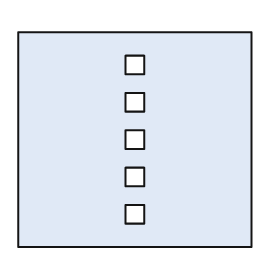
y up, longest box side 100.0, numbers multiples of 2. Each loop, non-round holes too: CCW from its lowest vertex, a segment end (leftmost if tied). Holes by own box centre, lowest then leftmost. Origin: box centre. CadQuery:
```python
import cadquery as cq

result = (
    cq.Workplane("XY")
    .moveTo(-50.0, -46.0)
    .lineTo(50.0, -46.0)
    .lineTo(50.0, 46.0)
    .lineTo(-50.0, 46.0)
    .close()
    .moveTo(-4.0, -36.0)
    .lineTo(4.0, -36.0)
    .lineTo(4.0, -28.0)
    .lineTo(-4.0, -28.0)
    .close()
    .moveTo(-4.0, -20.0)
    .lineTo(4.0, -20.0)
    .lineTo(4.0, -12.0)
    .lineTo(-4.0, -12.0)
    .close()
    .moveTo(-4.0, -4.0)
    .lineTo(4.0, -4.0)
    .lineTo(4.0, 4.0)
    .lineTo(-4.0, 4.0)
    .close()
    .moveTo(-4.0, 12.0)
    .lineTo(4.0, 12.0)
    .lineTo(4.0, 20.0)
    .lineTo(-4.0, 20.0)
    .close()
    .moveTo(-4.0, 28.0)
    .lineTo(4.0, 28.0)
    .lineTo(4.0, 36.0)
    .lineTo(-4.0, 36.0)
    .close()
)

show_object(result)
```